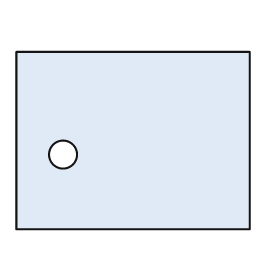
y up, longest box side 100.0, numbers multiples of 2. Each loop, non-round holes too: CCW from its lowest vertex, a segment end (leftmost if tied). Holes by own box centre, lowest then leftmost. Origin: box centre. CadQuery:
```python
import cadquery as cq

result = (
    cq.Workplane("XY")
    .moveTo(-50.0, -38.0)
    .lineTo(50.0, -38.0)
    .lineTo(50.0, 38.0)
    .lineTo(-50.0, 38.0)
    .close()
    .moveTo(-30.0, -6.0)
    .circle(6.0)
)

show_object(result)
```